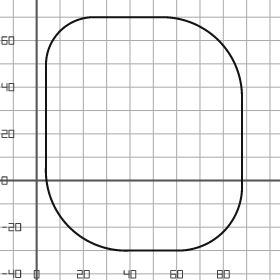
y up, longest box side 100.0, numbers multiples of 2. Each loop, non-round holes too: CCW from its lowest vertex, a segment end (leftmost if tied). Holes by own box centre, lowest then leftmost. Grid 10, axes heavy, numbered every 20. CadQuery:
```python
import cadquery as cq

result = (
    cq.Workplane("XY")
    .moveTo(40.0, -30.0)
    .lineTo(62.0, -30.0)
    .threePointArc((80.0, -22.0), (88.0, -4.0))
    .lineTo(88.0, 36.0)
    .threePointArc((78.0, 60.0), (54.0, 70.0))
    .lineTo(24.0, 70.0)
    .threePointArc((10.0, 64.0), (4.0, 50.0))
    .lineTo(4.0, 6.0)
    .threePointArc((14.0, -20.0), (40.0, -30.0))
    .close()
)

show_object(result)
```